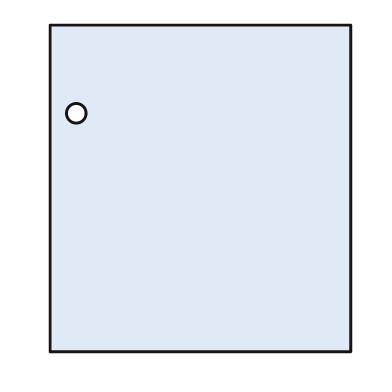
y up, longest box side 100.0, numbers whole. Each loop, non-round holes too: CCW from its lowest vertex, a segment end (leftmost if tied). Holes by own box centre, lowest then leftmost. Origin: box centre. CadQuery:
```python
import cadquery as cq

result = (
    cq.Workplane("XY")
    .moveTo(-46.0, -50.0)
    .lineTo(46.0, -50.0)
    .lineTo(46.0, 50.0)
    .lineTo(-46.0, 50.0)
    .close()
    .moveTo(-38.0, 23.0)
    .circle(3.0)
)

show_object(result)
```